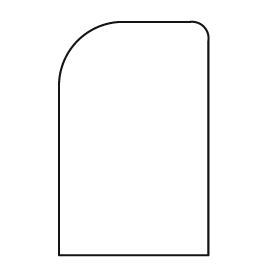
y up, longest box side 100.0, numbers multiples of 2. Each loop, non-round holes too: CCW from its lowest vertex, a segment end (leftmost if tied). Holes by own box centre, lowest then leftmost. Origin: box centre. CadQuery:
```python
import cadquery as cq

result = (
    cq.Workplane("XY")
    .moveTo(-32.0, -50.0)
    .lineTo(32.0, -50.0)
    .lineTo(32.0, 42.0)
    .threePointArc((30.0, 48.0), (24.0, 50.0))
    .lineTo(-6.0, 50.0)
    .threePointArc((-24.0, 42.0), (-32.0, 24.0))
    .close()
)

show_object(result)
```